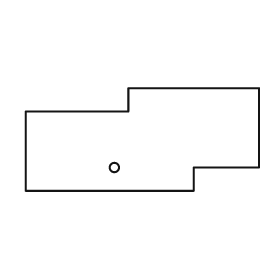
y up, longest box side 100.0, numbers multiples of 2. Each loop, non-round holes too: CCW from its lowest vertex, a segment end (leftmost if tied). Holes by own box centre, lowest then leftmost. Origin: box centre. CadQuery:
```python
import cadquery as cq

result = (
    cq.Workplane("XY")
    .moveTo(-50.0, -22.0)
    .lineTo(22.0, -22.0)
    .lineTo(22.0, -12.0)
    .lineTo(50.0, -12.0)
    .lineTo(50.0, 22.0)
    .lineTo(-6.0, 22.0)
    .lineTo(-6.0, 12.0)
    .lineTo(-50.0, 12.0)
    .close()
    .moveTo(-12.0, -12.0)
    .circle(2.0)
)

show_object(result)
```